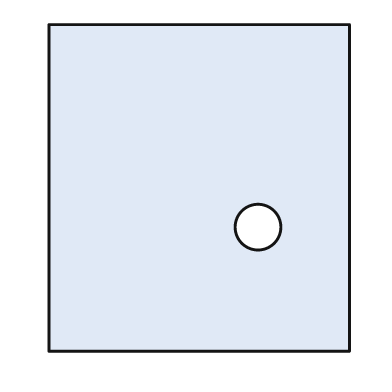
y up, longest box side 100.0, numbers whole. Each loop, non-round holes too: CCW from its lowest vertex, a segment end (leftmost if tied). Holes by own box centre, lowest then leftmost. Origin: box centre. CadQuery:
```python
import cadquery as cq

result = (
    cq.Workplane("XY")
    .moveTo(-46.0, -50.0)
    .lineTo(46.0, -50.0)
    .lineTo(46.0, 50.0)
    .lineTo(-46.0, 50.0)
    .close()
    .moveTo(18.0, -12.0)
    .circle(7.0)
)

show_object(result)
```